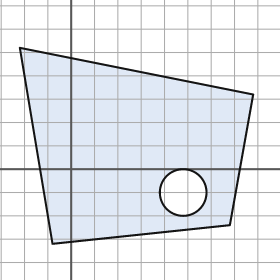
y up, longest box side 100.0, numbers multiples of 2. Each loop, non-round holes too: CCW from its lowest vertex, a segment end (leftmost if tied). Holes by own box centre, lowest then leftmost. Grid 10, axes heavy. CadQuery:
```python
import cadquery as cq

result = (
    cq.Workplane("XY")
    .moveTo(-8.0, -32.0)
    .lineTo(68.0, -24.0)
    .lineTo(78.0, 32.0)
    .lineTo(-22.0, 52.0)
    .close()
    .moveTo(48.0, -10.0)
    .circle(10.0)
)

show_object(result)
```